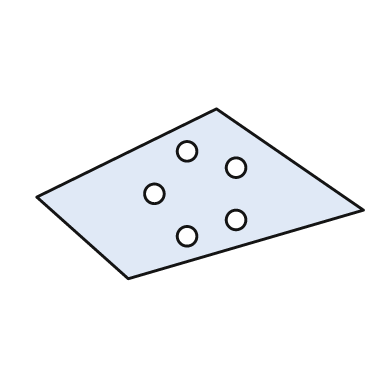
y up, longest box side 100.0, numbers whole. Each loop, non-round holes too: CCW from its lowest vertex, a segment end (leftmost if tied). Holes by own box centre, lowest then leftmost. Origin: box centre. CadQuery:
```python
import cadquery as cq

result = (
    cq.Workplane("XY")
    .moveTo(-22.0, -26.0)
    .lineTo(50.0, -5.0)
    .lineTo(5.0, 26.0)
    .lineTo(-50.0, -1.0)
    .close()
    .moveTo(-4.0, -13.0)
    .circle(3.0)
    .moveTo(11.0, -8.0)
    .circle(3.0)
    .moveTo(-14.0, 0.0)
    .circle(3.0)
    .moveTo(11.0, 8.0)
    .circle(3.0)
    .moveTo(-4.0, 13.0)
    .circle(3.0)
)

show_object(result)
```